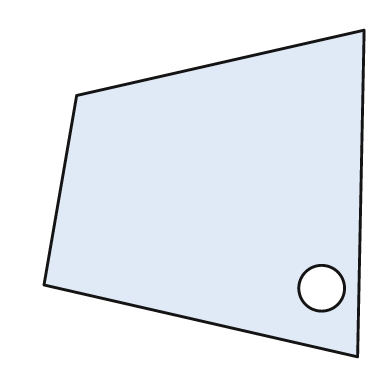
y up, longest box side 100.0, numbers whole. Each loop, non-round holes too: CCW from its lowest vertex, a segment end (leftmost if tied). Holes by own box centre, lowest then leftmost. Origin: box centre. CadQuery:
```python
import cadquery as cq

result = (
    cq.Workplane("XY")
    .moveTo(47.0, -50.0)
    .lineTo(49.0, 50.0)
    .lineTo(-39.0, 30.0)
    .lineTo(-49.0, -28.0)
    .close()
    .moveTo(36.0, -29.0)
    .circle(7.0)
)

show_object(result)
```